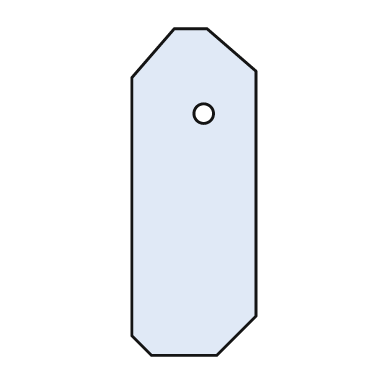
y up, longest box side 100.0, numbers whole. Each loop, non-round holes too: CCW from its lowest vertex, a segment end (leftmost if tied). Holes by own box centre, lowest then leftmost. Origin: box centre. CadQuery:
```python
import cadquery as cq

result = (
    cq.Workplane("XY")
    .moveTo(-13.0, -50.0)
    .lineTo(7.0, -50.0)
    .lineTo(19.0, -38.0)
    .lineTo(19.0, 37.0)
    .lineTo(4.0, 50.0)
    .lineTo(-6.0, 50.0)
    .lineTo(-19.0, 35.0)
    .lineTo(-19.0, -44.0)
    .close()
    .moveTo(3.0, 24.0)
    .circle(3.0)
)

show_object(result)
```